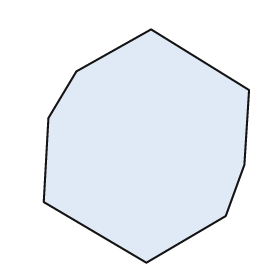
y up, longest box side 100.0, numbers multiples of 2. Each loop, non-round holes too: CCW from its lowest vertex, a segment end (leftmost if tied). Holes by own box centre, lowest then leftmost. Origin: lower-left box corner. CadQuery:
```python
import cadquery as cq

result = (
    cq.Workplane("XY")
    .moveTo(44.0, 0.0)
    .lineTo(78.0, 20.0)
    .lineTo(86.0, 42.0)
    .lineTo(88.0, 74.0)
    .lineTo(46.0, 100.0)
    .lineTo(14.0, 82.0)
    .lineTo(2.0, 62.0)
    .lineTo(0.0, 26.0)
    .close()
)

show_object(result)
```